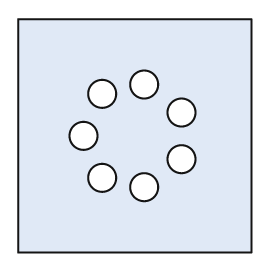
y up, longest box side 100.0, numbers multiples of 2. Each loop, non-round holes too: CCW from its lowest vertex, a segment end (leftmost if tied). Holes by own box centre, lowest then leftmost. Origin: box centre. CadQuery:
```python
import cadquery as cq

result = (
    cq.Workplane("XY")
    .moveTo(-50.0, -50.0)
    .lineTo(50.0, -50.0)
    .lineTo(50.0, 50.0)
    .lineTo(-50.0, 50.0)
    .close()
    .moveTo(4.0, -22.0)
    .circle(6.0)
    .moveTo(-14.0, -18.0)
    .circle(6.0)
    .moveTo(20.0, -10.0)
    .circle(6.0)
    .moveTo(-22.0, 0.0)
    .circle(6.0)
    .moveTo(20.0, 10.0)
    .circle(6.0)
    .moveTo(-14.0, 18.0)
    .circle(6.0)
    .moveTo(4.0, 22.0)
    .circle(6.0)
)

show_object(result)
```